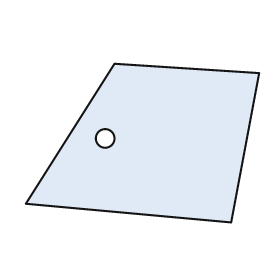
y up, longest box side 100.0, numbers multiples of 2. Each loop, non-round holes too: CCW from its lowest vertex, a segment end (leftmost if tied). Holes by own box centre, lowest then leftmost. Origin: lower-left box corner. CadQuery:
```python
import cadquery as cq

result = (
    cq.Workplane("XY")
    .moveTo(88.0, 0.0)
    .lineTo(100.0, 64.0)
    .lineTo(38.0, 68.0)
    .lineTo(0.0, 8.0)
    .close()
    .moveTo(34.0, 36.0)
    .circle(4.0)
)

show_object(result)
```